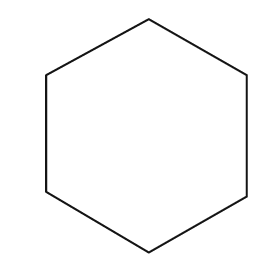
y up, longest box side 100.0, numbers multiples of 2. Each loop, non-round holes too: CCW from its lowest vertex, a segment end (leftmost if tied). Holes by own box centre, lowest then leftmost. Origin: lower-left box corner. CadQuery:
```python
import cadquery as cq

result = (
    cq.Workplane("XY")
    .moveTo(44.0, 0.0)
    .lineTo(86.0, 24.0)
    .lineTo(86.0, 76.0)
    .lineTo(44.0, 100.0)
    .lineTo(0.0, 76.0)
    .lineTo(0.0, 26.0)
    .close()
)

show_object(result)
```